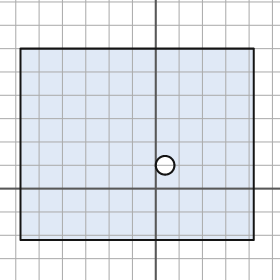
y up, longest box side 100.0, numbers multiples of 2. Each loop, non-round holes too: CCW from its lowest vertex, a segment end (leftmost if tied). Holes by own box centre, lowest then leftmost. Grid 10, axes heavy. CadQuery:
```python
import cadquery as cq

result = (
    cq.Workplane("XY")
    .moveTo(-58.0, -22.0)
    .lineTo(42.0, -22.0)
    .lineTo(42.0, 60.0)
    .lineTo(-58.0, 60.0)
    .close()
    .moveTo(4.0, 10.0)
    .circle(4.0)
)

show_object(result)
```